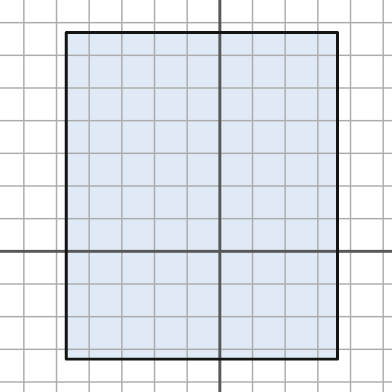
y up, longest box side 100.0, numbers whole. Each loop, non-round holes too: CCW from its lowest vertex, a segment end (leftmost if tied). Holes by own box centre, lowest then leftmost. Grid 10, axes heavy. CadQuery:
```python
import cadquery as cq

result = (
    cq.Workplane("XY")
    .moveTo(-47.0, -33.0)
    .lineTo(36.0, -33.0)
    .lineTo(36.0, 67.0)
    .lineTo(-47.0, 67.0)
    .close()
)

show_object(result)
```